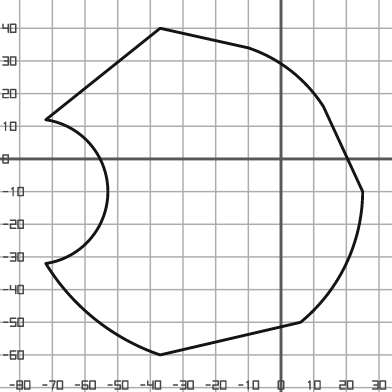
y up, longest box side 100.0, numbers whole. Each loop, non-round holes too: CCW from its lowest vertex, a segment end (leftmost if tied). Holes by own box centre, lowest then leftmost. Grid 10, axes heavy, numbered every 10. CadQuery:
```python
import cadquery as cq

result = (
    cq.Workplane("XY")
    .moveTo(-37.0, -60.0)
    .lineTo(6.0, -50.0)
    .threePointArc((20.0, -32.0), (25.0, -10.0))
    .lineTo(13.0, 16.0)
    .threePointArc((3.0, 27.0), (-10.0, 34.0))
    .lineTo(-37.0, 40.0)
    .lineTo(-72.0, 12.0)
    .threePointArc((-53.0, -10.0), (-72.0, -32.0))
    .threePointArc((-57.0, -49.0), (-37.0, -60.0))
    .close()
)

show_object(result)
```